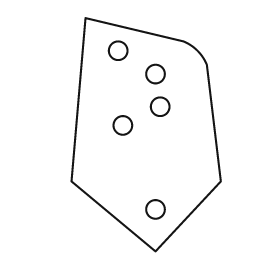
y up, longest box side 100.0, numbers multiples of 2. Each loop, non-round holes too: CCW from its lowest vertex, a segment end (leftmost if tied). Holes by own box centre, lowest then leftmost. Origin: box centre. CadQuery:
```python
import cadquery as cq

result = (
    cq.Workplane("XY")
    .moveTo(4.0, -50.0)
    .lineTo(32.0, -20.0)
    .lineTo(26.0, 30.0)
    .threePointArc((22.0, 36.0), (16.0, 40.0))
    .lineTo(-26.0, 50.0)
    .lineTo(-32.0, -20.0)
    .close()
    .moveTo(4.0, -32.0)
    .circle(4.0)
    .moveTo(-10.0, 4.0)
    .circle(4.0)
    .moveTo(6.0, 12.0)
    .circle(4.0)
    .moveTo(4.0, 26.0)
    .circle(4.0)
    .moveTo(-12.0, 36.0)
    .circle(4.0)
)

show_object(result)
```